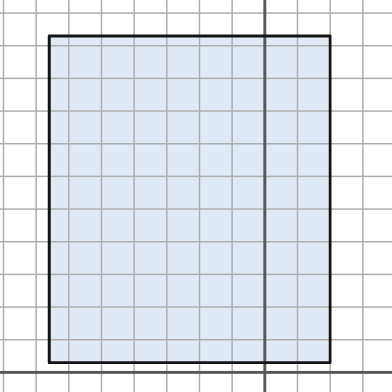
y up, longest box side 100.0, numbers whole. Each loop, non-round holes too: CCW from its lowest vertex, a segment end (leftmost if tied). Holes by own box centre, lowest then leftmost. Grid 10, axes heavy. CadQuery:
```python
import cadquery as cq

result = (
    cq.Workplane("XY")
    .moveTo(-66.0, 3.0)
    .lineTo(20.0, 3.0)
    .lineTo(20.0, 103.0)
    .lineTo(-66.0, 103.0)
    .close()
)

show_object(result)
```